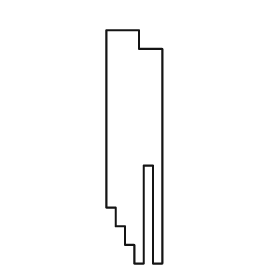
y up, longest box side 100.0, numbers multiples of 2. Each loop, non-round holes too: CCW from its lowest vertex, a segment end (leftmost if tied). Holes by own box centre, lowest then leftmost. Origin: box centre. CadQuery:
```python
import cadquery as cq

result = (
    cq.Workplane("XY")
    .moveTo(0.0, -50.0)
    .lineTo(4.0, -50.0)
    .lineTo(4.0, -8.0)
    .lineTo(8.0, -8.0)
    .lineTo(8.0, -50.0)
    .lineTo(12.0, -50.0)
    .lineTo(12.0, 42.0)
    .lineTo(2.0, 42.0)
    .lineTo(2.0, 50.0)
    .lineTo(-12.0, 50.0)
    .lineTo(-12.0, -26.0)
    .lineTo(-8.0, -26.0)
    .lineTo(-8.0, -34.0)
    .lineTo(-4.0, -34.0)
    .lineTo(-4.0, -42.0)
    .lineTo(0.0, -42.0)
    .close()
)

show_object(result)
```